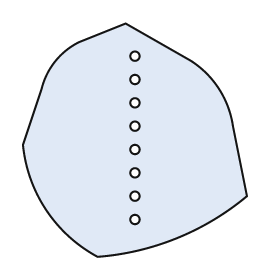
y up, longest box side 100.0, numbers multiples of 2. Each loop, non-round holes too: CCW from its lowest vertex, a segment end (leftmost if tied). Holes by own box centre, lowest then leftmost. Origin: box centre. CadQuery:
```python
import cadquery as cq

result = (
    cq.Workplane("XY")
    .moveTo(-16.0, -50.0)
    .threePointArc((18.0, -42.0), (48.0, -24.0))
    .lineTo(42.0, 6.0)
    .threePointArc((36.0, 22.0), (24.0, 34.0))
    .lineTo(-4.0, 50.0)
    .lineTo(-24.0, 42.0)
    .threePointArc((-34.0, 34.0), (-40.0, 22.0))
    .lineTo(-48.0, -2.0)
    .threePointArc((-38.0, -30.0), (-16.0, -50.0))
    .close()
    .moveTo(0.0, -34.0)
    .circle(2.0)
    .moveTo(0.0, -24.0)
    .circle(2.0)
    .moveTo(0.0, -14.0)
    .circle(2.0)
    .moveTo(0.0, -4.0)
    .circle(2.0)
    .moveTo(0.0, 6.0)
    .circle(2.0)
    .moveTo(0.0, 16.0)
    .circle(2.0)
    .moveTo(0.0, 26.0)
    .circle(2.0)
    .moveTo(0.0, 36.0)
    .circle(2.0)
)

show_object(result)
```